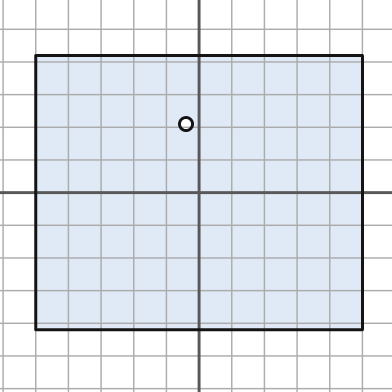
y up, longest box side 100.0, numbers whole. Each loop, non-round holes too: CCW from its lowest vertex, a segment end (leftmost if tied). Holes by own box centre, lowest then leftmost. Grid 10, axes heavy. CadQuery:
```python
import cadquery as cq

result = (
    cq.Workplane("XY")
    .moveTo(-50.0, -42.0)
    .lineTo(50.0, -42.0)
    .lineTo(50.0, 42.0)
    .lineTo(-50.0, 42.0)
    .close()
    .moveTo(-4.0, 21.0)
    .circle(2.0)
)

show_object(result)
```